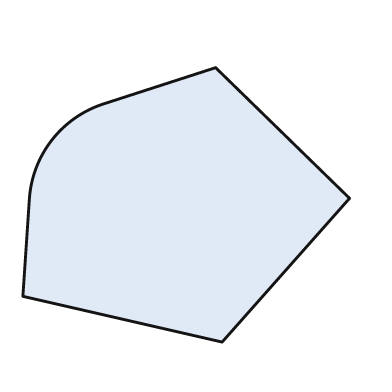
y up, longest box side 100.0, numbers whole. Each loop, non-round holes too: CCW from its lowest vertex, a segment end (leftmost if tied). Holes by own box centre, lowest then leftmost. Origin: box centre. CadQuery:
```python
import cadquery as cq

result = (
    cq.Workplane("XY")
    .moveTo(11.0, -42.0)
    .lineTo(50.0, 2.0)
    .lineTo(9.0, 42.0)
    .lineTo(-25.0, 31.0)
    .threePointArc((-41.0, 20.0), (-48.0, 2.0))
    .lineTo(-50.0, -28.0)
    .close()
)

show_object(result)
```